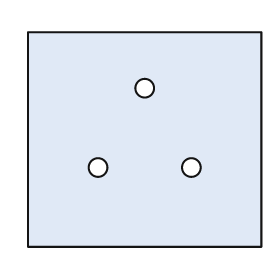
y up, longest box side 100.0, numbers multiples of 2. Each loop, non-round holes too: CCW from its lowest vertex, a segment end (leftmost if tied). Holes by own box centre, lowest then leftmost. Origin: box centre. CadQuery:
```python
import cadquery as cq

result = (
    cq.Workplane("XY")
    .moveTo(-50.0, -46.0)
    .lineTo(50.0, -46.0)
    .lineTo(50.0, 46.0)
    .lineTo(-50.0, 46.0)
    .close()
    .moveTo(-20.0, -12.0)
    .circle(4.0)
    .moveTo(20.0, -12.0)
    .circle(4.0)
    .moveTo(0.0, 22.0)
    .circle(4.0)
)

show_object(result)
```